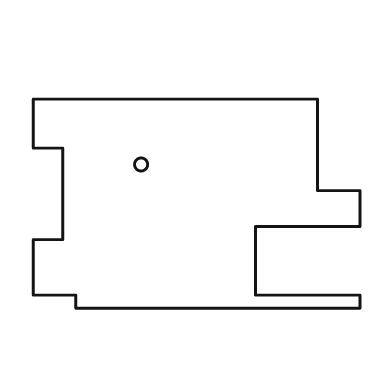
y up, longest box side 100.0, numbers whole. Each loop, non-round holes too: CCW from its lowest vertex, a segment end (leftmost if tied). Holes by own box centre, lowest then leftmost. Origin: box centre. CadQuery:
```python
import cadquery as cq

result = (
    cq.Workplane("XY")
    .moveTo(-37.0, -32.0)
    .lineTo(50.0, -32.0)
    .lineTo(50.0, -28.0)
    .lineTo(18.0, -28.0)
    .lineTo(18.0, -7.0)
    .lineTo(50.0, -7.0)
    .lineTo(50.0, 4.0)
    .lineTo(37.0, 4.0)
    .lineTo(37.0, 32.0)
    .lineTo(-50.0, 32.0)
    .lineTo(-50.0, 17.0)
    .lineTo(-41.0, 17.0)
    .lineTo(-41.0, -11.0)
    .lineTo(-50.0, -11.0)
    .lineTo(-50.0, -28.0)
    .lineTo(-37.0, -28.0)
    .close()
    .moveTo(-17.0, 12.0)
    .circle(2.0)
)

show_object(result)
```